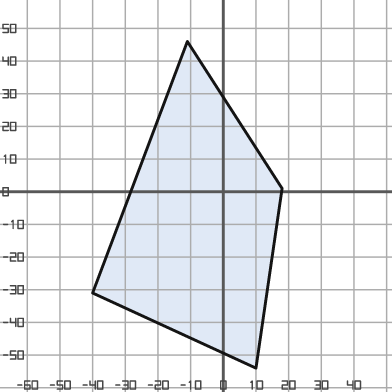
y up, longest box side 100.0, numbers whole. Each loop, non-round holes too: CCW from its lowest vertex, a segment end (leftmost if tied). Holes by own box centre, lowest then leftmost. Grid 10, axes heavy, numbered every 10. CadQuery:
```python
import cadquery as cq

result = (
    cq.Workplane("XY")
    .moveTo(10.0, -54.0)
    .lineTo(18.0, 1.0)
    .lineTo(-11.0, 46.0)
    .lineTo(-40.0, -31.0)
    .close()
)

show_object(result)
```